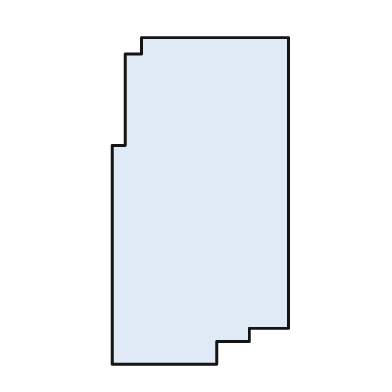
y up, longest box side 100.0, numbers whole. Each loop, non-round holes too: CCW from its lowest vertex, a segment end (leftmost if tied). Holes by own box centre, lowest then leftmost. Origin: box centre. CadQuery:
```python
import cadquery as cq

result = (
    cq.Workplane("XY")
    .moveTo(-27.0, -50.0)
    .lineTo(5.0, -50.0)
    .lineTo(5.0, -43.0)
    .lineTo(15.0, -43.0)
    .lineTo(15.0, -39.0)
    .lineTo(27.0, -39.0)
    .lineTo(27.0, 50.0)
    .lineTo(-18.0, 50.0)
    .lineTo(-18.0, 45.0)
    .lineTo(-23.0, 45.0)
    .lineTo(-23.0, 17.0)
    .lineTo(-27.0, 17.0)
    .close()
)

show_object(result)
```